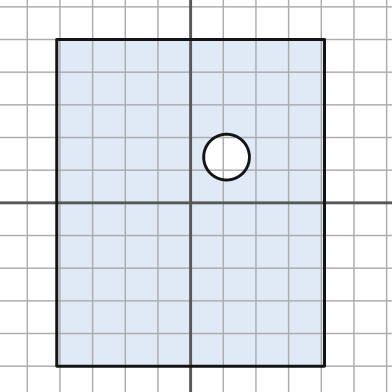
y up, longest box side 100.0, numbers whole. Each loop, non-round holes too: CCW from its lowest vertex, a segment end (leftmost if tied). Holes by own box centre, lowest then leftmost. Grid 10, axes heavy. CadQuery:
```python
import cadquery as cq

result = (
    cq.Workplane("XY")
    .moveTo(-41.0, -50.0)
    .lineTo(41.0, -50.0)
    .lineTo(41.0, 50.0)
    .lineTo(-41.0, 50.0)
    .close()
    .moveTo(11.0, 14.0)
    .circle(7.0)
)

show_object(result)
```